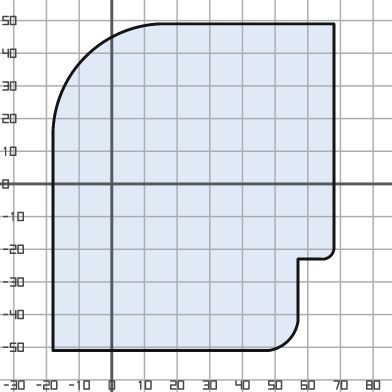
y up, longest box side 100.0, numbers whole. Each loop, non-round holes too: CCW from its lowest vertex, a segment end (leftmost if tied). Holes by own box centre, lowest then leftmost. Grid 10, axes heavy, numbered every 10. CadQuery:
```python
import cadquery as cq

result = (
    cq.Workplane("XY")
    .moveTo(-18.0, -51.0)
    .lineTo(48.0, -51.0)
    .threePointArc((54.0, -48.0), (57.0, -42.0))
    .lineTo(57.0, -23.0)
    .lineTo(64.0, -23.0)
    .threePointArc((67.0, -22.0), (68.0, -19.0))
    .lineTo(68.0, 49.0)
    .lineTo(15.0, 49.0)
    .threePointArc((-8.0, 39.0), (-18.0, 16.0))
    .close()
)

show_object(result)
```